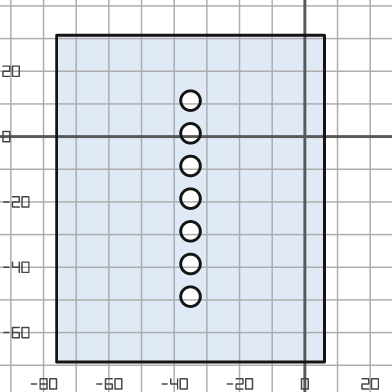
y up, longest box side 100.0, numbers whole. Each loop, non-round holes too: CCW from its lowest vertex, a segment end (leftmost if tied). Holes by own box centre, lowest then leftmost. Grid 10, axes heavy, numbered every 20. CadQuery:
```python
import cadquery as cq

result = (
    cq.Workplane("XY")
    .moveTo(-76.0, -69.0)
    .lineTo(6.0, -69.0)
    .lineTo(6.0, 31.0)
    .lineTo(-76.0, 31.0)
    .close()
    .moveTo(-35.0, -49.0)
    .circle(3.0)
    .moveTo(-35.0, -39.0)
    .circle(3.0)
    .moveTo(-35.0, -29.0)
    .circle(3.0)
    .moveTo(-35.0, -19.0)
    .circle(3.0)
    .moveTo(-35.0, -9.0)
    .circle(3.0)
    .moveTo(-35.0, 1.0)
    .circle(3.0)
    .moveTo(-35.0, 11.0)
    .circle(3.0)
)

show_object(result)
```